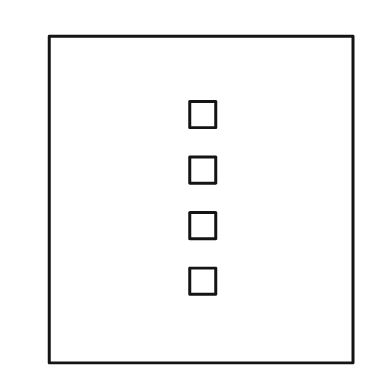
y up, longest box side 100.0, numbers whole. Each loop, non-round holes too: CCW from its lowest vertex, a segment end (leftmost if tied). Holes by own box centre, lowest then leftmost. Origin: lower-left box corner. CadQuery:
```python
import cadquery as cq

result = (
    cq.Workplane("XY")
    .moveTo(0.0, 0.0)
    .lineTo(93.0, 0.0)
    .lineTo(93.0, 100.0)
    .lineTo(0.0, 100.0)
    .close()
    .moveTo(43.0, 21.0)
    .lineTo(51.0, 21.0)
    .lineTo(51.0, 29.0)
    .lineTo(43.0, 29.0)
    .close()
    .moveTo(43.0, 38.0)
    .lineTo(51.0, 38.0)
    .lineTo(51.0, 46.0)
    .lineTo(43.0, 46.0)
    .close()
    .moveTo(43.0, 55.0)
    .lineTo(51.0, 55.0)
    .lineTo(51.0, 63.0)
    .lineTo(43.0, 63.0)
    .close()
    .moveTo(43.0, 72.0)
    .lineTo(51.0, 72.0)
    .lineTo(51.0, 80.0)
    .lineTo(43.0, 80.0)
    .close()
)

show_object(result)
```